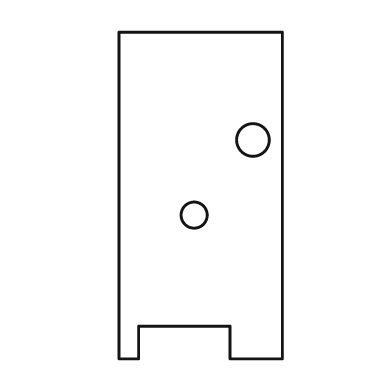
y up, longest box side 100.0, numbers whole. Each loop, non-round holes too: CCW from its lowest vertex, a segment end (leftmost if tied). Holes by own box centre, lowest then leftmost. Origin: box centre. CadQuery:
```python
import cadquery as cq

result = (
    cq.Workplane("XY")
    .moveTo(-25.0, -50.0)
    .lineTo(-19.0, -50.0)
    .lineTo(-19.0, -40.0)
    .lineTo(9.0, -40.0)
    .lineTo(9.0, -50.0)
    .lineTo(25.0, -50.0)
    .lineTo(25.0, 50.0)
    .lineTo(-25.0, 50.0)
    .close()
    .moveTo(-2.0, -6.0)
    .circle(4.0)
    .moveTo(16.0, 17.0)
    .circle(5.0)
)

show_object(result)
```